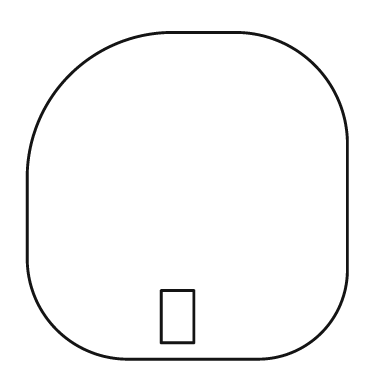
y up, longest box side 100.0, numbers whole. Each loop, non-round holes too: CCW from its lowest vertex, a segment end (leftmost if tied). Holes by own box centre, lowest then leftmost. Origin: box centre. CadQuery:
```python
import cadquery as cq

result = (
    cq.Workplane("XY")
    .moveTo(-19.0, -50.0)
    .lineTo(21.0, -50.0)
    .threePointArc((41.0, -42.0), (49.0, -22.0))
    .lineTo(49.0, 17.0)
    .threePointArc((39.0, 40.0), (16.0, 50.0))
    .lineTo(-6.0, 50.0)
    .threePointArc((-36.0, 37.0), (-49.0, 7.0))
    .lineTo(-49.0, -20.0)
    .threePointArc((-40.0, -41.0), (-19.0, -50.0))
    .close()
    .moveTo(-8.0, -45.0)
    .lineTo(2.0, -45.0)
    .lineTo(2.0, -29.0)
    .lineTo(-8.0, -29.0)
    .close()
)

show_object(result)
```